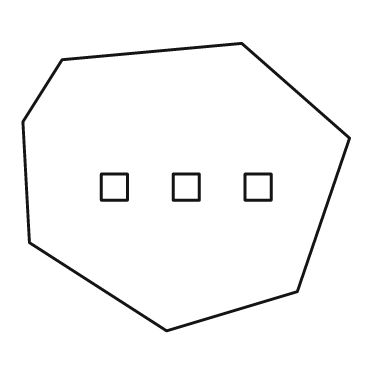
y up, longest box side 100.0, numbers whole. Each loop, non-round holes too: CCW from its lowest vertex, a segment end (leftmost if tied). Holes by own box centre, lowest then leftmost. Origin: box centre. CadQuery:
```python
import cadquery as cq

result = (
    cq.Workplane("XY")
    .moveTo(-6.0, -44.0)
    .lineTo(34.0, -32.0)
    .lineTo(50.0, 15.0)
    .lineTo(17.0, 44.0)
    .lineTo(-38.0, 39.0)
    .lineTo(-50.0, 20.0)
    .lineTo(-48.0, -17.0)
    .close()
    .moveTo(-26.0, -4.0)
    .lineTo(-18.0, -4.0)
    .lineTo(-18.0, 4.0)
    .lineTo(-26.0, 4.0)
    .close()
    .moveTo(-4.0, -4.0)
    .lineTo(4.0, -4.0)
    .lineTo(4.0, 4.0)
    .lineTo(-4.0, 4.0)
    .close()
    .moveTo(18.0, -4.0)
    .lineTo(26.0, -4.0)
    .lineTo(26.0, 4.0)
    .lineTo(18.0, 4.0)
    .close()
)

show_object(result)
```